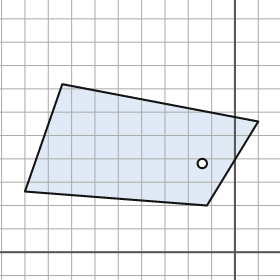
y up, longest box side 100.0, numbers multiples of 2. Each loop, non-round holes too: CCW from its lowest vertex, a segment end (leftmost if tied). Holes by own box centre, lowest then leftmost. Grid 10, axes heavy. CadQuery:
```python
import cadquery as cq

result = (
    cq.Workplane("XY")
    .moveTo(-12.0, 20.0)
    .lineTo(10.0, 56.0)
    .lineTo(-74.0, 72.0)
    .lineTo(-90.0, 26.0)
    .close()
    .moveTo(-14.0, 38.0)
    .circle(2.0)
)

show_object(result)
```